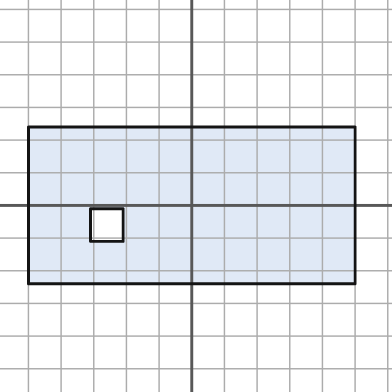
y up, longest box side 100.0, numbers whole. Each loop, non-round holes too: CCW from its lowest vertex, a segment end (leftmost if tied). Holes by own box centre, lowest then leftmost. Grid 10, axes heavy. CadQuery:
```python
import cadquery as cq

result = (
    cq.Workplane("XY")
    .moveTo(-50.0, -24.0)
    .lineTo(50.0, -24.0)
    .lineTo(50.0, 24.0)
    .lineTo(-50.0, 24.0)
    .close()
    .moveTo(-31.0, -11.0)
    .lineTo(-21.0, -11.0)
    .lineTo(-21.0, -1.0)
    .lineTo(-31.0, -1.0)
    .close()
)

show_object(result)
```